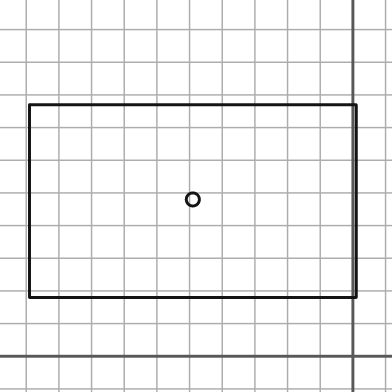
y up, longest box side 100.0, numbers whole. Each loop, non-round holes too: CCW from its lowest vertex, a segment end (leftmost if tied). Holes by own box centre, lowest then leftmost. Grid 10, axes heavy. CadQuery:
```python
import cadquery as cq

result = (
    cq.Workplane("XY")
    .moveTo(-99.0, 18.0)
    .lineTo(1.0, 18.0)
    .lineTo(1.0, 77.0)
    .lineTo(-99.0, 77.0)
    .close()
    .moveTo(-49.0, 48.0)
    .circle(2.0)
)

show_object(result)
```